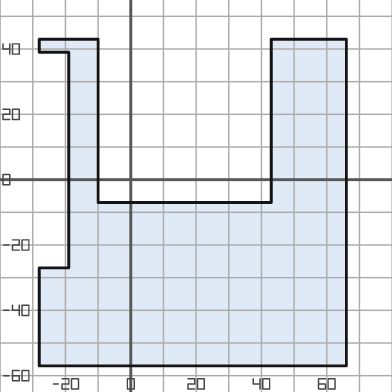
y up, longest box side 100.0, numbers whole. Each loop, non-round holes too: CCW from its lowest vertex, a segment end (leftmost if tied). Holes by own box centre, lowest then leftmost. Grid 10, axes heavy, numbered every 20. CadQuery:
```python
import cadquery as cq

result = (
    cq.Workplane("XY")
    .moveTo(-28.0, -57.0)
    .lineTo(66.0, -57.0)
    .lineTo(66.0, 43.0)
    .lineTo(43.0, 43.0)
    .lineTo(43.0, -7.0)
    .lineTo(-10.0, -7.0)
    .lineTo(-10.0, 43.0)
    .lineTo(-28.0, 43.0)
    .lineTo(-28.0, 39.0)
    .lineTo(-19.0, 39.0)
    .lineTo(-19.0, -27.0)
    .lineTo(-28.0, -27.0)
    .close()
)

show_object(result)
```